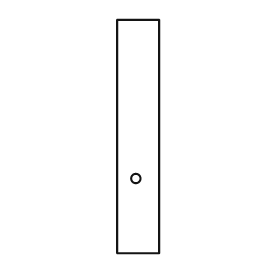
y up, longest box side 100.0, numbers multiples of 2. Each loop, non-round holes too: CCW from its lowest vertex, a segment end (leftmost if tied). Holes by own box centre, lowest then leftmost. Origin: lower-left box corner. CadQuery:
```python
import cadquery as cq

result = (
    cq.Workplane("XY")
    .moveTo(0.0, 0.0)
    .lineTo(18.0, 0.0)
    .lineTo(18.0, 100.0)
    .lineTo(0.0, 100.0)
    .close()
    .moveTo(8.0, 32.0)
    .circle(2.0)
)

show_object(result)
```